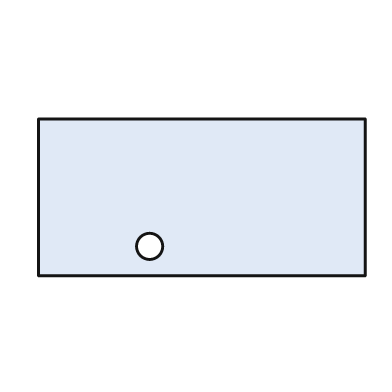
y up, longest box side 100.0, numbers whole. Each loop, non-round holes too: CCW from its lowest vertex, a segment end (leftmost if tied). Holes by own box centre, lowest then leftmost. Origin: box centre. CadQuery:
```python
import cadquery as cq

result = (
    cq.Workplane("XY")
    .moveTo(-50.0, -24.0)
    .lineTo(50.0, -24.0)
    .lineTo(50.0, 24.0)
    .lineTo(-50.0, 24.0)
    .close()
    .moveTo(-16.0, -15.0)
    .circle(4.0)
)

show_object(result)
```